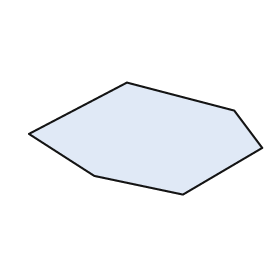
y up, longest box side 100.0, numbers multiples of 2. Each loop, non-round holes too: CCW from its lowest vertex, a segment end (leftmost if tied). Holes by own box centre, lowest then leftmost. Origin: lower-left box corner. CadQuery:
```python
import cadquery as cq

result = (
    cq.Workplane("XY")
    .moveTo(66.0, 0.0)
    .lineTo(100.0, 20.0)
    .lineTo(88.0, 36.0)
    .lineTo(42.0, 48.0)
    .lineTo(0.0, 26.0)
    .lineTo(28.0, 8.0)
    .close()
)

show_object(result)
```